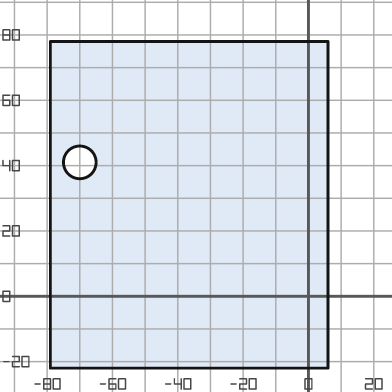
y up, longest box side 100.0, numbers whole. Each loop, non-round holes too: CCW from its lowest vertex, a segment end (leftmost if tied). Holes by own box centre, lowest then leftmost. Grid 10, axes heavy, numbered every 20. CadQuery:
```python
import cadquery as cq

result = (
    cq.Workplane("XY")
    .moveTo(-79.0, -22.0)
    .lineTo(6.0, -22.0)
    .lineTo(6.0, 78.0)
    .lineTo(-79.0, 78.0)
    .close()
    .moveTo(-70.0, 41.0)
    .circle(5.0)
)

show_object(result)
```